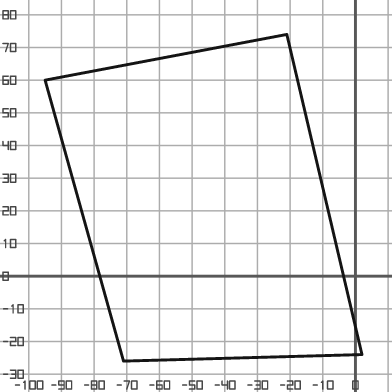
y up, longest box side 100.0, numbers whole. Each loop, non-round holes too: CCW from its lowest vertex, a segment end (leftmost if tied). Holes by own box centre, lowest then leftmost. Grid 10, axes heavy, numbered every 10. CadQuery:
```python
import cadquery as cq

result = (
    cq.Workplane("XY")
    .moveTo(-71.0, -26.0)
    .lineTo(2.0, -24.0)
    .lineTo(-21.0, 74.0)
    .lineTo(-95.0, 60.0)
    .close()
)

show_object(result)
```